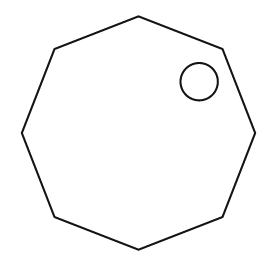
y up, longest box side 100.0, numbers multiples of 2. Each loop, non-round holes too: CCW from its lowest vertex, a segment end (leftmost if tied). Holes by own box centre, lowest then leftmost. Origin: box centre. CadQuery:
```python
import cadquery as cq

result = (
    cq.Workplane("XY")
    .moveTo(0.0, -50.0)
    .lineTo(36.0, -36.0)
    .lineTo(50.0, 0.0)
    .lineTo(36.0, 36.0)
    .lineTo(0.0, 50.0)
    .lineTo(-36.0, 36.0)
    .lineTo(-50.0, 0.0)
    .lineTo(-36.0, -36.0)
    .close()
    .moveTo(26.0, 22.0)
    .circle(8.0)
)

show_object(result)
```